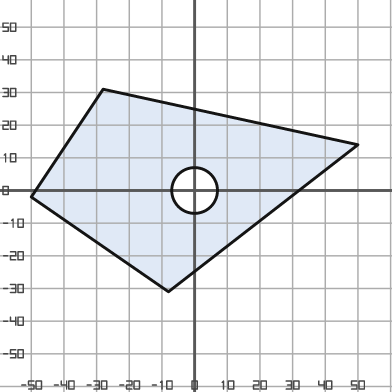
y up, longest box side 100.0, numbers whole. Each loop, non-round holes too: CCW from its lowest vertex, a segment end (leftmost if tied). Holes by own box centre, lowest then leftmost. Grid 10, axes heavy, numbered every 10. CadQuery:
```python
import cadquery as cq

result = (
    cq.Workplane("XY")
    .moveTo(-8.0, -31.0)
    .lineTo(50.0, 14.0)
    .lineTo(-28.0, 31.0)
    .lineTo(-50.0, -2.0)
    .close()
    .moveTo(0.0, 0.0)
    .circle(7.0)
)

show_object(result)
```